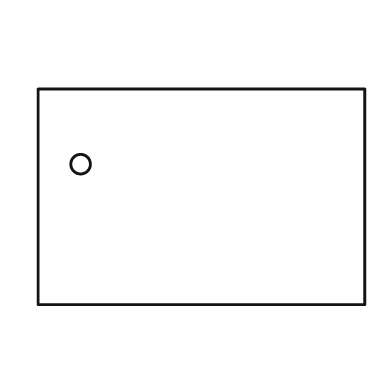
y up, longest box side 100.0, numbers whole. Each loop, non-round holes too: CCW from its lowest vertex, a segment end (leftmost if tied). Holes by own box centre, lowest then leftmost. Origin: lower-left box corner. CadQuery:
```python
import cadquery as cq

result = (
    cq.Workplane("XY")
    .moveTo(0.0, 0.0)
    .lineTo(100.0, 0.0)
    .lineTo(100.0, 66.0)
    .lineTo(0.0, 66.0)
    .close()
    .moveTo(13.0, 43.0)
    .circle(3.0)
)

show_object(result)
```